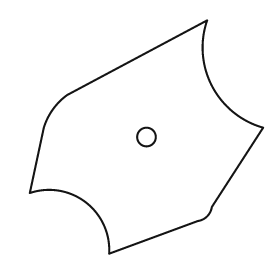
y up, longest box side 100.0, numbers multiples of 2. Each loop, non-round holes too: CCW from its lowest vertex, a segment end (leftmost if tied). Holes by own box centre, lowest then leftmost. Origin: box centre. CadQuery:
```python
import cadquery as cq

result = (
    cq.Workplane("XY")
    .moveTo(-16.0, -50.0)
    .lineTo(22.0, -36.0)
    .threePointArc((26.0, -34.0), (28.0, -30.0))
    .lineTo(50.0, 4.0)
    .threePointArc((28.0, 22.0), (26.0, 50.0))
    .lineTo(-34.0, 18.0)
    .threePointArc((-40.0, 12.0), (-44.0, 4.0))
    .lineTo(-50.0, -24.0)
    .threePointArc((-26.0, -28.0), (-16.0, -50.0))
    .close()
    .moveTo(0.0, 0.0)
    .circle(4.0)
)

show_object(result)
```